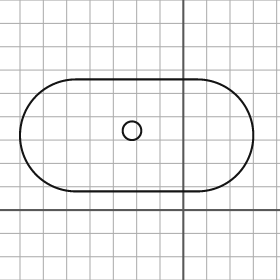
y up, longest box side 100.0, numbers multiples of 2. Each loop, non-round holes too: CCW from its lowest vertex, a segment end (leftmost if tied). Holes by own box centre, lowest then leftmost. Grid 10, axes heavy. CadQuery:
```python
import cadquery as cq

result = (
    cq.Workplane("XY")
    .moveTo(-46.0, 8.0)
    .lineTo(6.0, 8.0)
    .threePointArc((30.0, 32.0), (6.0, 56.0))
    .lineTo(-46.0, 56.0)
    .threePointArc((-70.0, 32.0), (-46.0, 8.0))
    .close()
    .moveTo(-22.0, 34.0)
    .circle(4.0)
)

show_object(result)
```